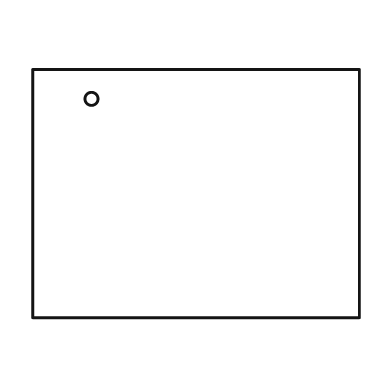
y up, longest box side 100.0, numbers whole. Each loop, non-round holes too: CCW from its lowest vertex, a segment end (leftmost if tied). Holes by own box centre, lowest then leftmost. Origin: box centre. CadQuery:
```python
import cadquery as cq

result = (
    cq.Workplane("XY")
    .moveTo(-50.0, -38.0)
    .lineTo(50.0, -38.0)
    .lineTo(50.0, 38.0)
    .lineTo(-50.0, 38.0)
    .close()
    .moveTo(-32.0, 29.0)
    .circle(2.0)
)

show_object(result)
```